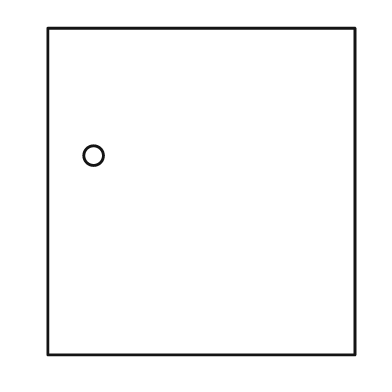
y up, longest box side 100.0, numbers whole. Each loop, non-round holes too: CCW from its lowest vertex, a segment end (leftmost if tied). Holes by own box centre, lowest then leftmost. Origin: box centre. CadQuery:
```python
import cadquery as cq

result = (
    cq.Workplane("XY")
    .moveTo(-47.0, -50.0)
    .lineTo(47.0, -50.0)
    .lineTo(47.0, 50.0)
    .lineTo(-47.0, 50.0)
    .close()
    .moveTo(-33.0, 11.0)
    .circle(3.0)
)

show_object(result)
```